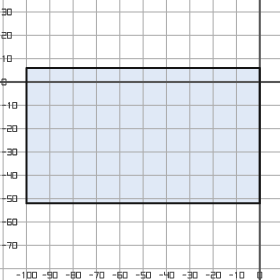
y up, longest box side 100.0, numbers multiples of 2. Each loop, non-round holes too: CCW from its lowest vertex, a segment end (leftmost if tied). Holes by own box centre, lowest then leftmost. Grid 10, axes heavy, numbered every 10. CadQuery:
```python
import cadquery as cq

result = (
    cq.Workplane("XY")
    .moveTo(-100.0, -52.0)
    .lineTo(0.0, -52.0)
    .lineTo(0.0, 6.0)
    .lineTo(-100.0, 6.0)
    .close()
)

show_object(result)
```